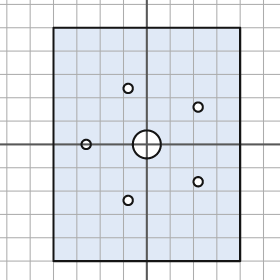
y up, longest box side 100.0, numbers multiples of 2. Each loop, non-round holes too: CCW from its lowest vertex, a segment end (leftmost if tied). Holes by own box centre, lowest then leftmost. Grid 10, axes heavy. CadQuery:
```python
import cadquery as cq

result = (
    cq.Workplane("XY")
    .moveTo(-40.0, -50.0)
    .lineTo(40.0, -50.0)
    .lineTo(40.0, 50.0)
    .lineTo(-40.0, 50.0)
    .close()
    .moveTo(-8.0, -24.0)
    .circle(2.0)
    .moveTo(22.0, -16.0)
    .circle(2.0)
    .moveTo(-26.0, 0.0)
    .circle(2.0)
    .moveTo(0.0, 0.0)
    .circle(6.0)
    .moveTo(22.0, 16.0)
    .circle(2.0)
    .moveTo(-8.0, 24.0)
    .circle(2.0)
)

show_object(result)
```